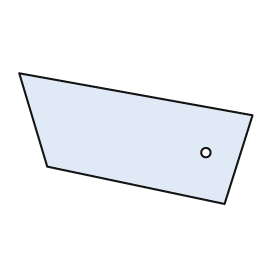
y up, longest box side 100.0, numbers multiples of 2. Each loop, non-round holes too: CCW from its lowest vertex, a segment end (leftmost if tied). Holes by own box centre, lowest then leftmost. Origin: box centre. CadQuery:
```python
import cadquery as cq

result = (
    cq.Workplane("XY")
    .moveTo(38.0, -28.0)
    .lineTo(50.0, 10.0)
    .lineTo(-50.0, 28.0)
    .lineTo(-38.0, -12.0)
    .close()
    .moveTo(30.0, -6.0)
    .circle(2.0)
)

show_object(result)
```